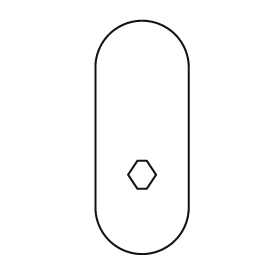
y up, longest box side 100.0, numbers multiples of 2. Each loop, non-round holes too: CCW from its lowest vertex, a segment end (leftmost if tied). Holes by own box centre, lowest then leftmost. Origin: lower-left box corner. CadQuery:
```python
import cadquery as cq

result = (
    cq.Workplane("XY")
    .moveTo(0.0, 20.0)
    .threePointArc((20.0, 0.0), (40.0, 20.0))
    .lineTo(40.0, 80.0)
    .threePointArc((20.0, 100.0), (0.0, 80.0))
    .close()
    .moveTo(18.0, 28.0)
    .lineTo(22.0, 28.0)
    .lineTo(26.0, 34.0)
    .lineTo(22.0, 40.0)
    .lineTo(18.0, 40.0)
    .lineTo(14.0, 34.0)
    .close()
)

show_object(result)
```